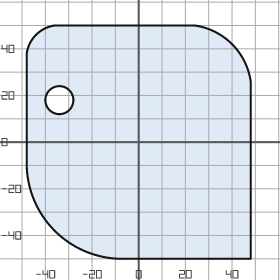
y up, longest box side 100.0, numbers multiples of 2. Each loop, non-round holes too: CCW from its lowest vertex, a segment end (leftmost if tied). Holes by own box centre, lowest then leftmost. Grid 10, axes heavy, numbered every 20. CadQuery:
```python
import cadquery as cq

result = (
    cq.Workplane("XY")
    .moveTo(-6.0, -50.0)
    .lineTo(48.0, -50.0)
    .lineTo(48.0, 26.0)
    .threePointArc((40.0, 42.0), (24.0, 50.0))
    .lineTo(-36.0, 50.0)
    .threePointArc((-44.0, 46.0), (-48.0, 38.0))
    .lineTo(-48.0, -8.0)
    .threePointArc((-36.0, -38.0), (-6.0, -50.0))
    .close()
    .moveTo(-34.0, 18.0)
    .circle(6.0)
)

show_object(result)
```